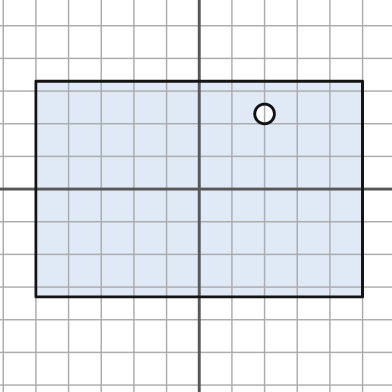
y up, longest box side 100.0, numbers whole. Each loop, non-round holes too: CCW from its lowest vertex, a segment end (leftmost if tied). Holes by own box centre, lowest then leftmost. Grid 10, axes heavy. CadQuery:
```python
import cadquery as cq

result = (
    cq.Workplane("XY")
    .moveTo(-50.0, -33.0)
    .lineTo(50.0, -33.0)
    .lineTo(50.0, 33.0)
    .lineTo(-50.0, 33.0)
    .close()
    .moveTo(20.0, 23.0)
    .circle(3.0)
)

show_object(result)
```